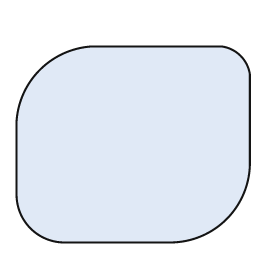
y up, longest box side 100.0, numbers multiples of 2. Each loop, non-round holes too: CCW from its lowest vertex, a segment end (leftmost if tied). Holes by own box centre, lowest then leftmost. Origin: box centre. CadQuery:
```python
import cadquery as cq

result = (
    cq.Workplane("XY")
    .moveTo(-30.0, -42.0)
    .lineTo(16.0, -42.0)
    .threePointArc((40.0, -32.0), (50.0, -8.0))
    .lineTo(50.0, 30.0)
    .threePointArc((46.0, 38.0), (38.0, 42.0))
    .lineTo(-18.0, 42.0)
    .threePointArc((-40.0, 32.0), (-50.0, 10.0))
    .lineTo(-50.0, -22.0)
    .threePointArc((-44.0, -36.0), (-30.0, -42.0))
    .close()
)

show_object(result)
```